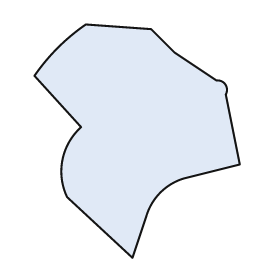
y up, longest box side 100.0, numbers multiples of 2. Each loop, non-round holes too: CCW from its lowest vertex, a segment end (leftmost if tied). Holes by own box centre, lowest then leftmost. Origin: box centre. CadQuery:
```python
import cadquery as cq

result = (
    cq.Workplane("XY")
    .moveTo(-2.0, -50.0)
    .lineTo(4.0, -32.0)
    .threePointArc((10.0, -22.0), (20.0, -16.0))
    .lineTo(44.0, -10.0)
    .lineTo(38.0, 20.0)
    .threePointArc((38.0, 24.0), (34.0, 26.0))
    .lineTo(16.0, 38.0)
    .lineTo(6.0, 48.0)
    .lineTo(-22.0, 50.0)
    .threePointArc((-34.0, 40.0), (-44.0, 28.0))
    .lineTo(-24.0, 6.0)
    .threePointArc((-32.0, -8.0), (-30.0, -24.0))
    .close()
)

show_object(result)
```